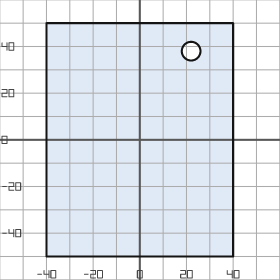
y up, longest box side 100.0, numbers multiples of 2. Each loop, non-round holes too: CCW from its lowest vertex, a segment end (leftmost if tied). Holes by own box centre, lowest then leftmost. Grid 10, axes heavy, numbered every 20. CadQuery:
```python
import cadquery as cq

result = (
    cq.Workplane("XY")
    .moveTo(-40.0, -50.0)
    .lineTo(40.0, -50.0)
    .lineTo(40.0, 50.0)
    .lineTo(-40.0, 50.0)
    .close()
    .moveTo(22.0, 38.0)
    .circle(4.0)
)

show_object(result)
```